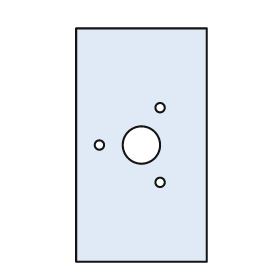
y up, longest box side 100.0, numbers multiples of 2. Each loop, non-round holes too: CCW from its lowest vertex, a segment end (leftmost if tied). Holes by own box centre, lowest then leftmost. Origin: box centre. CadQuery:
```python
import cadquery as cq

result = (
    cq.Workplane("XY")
    .moveTo(-28.0, -50.0)
    .lineTo(28.0, -50.0)
    .lineTo(28.0, 50.0)
    .lineTo(-28.0, 50.0)
    .close()
    .moveTo(8.0, -16.0)
    .circle(2.0)
    .moveTo(-18.0, 0.0)
    .circle(2.0)
    .moveTo(0.0, 0.0)
    .circle(8.0)
    .moveTo(8.0, 16.0)
    .circle(2.0)
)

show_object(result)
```